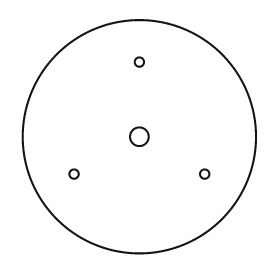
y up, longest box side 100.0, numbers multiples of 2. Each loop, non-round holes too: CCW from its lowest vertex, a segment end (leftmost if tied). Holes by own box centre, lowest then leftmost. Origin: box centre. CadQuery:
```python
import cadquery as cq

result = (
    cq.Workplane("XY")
    .moveTo(0.0, 0.0)
    .circle(50.0)
    .moveTo(-28.0, -16.0)
    .circle(2.0)
    .moveTo(28.0, -16.0)
    .circle(2.0)
    .moveTo(0.0, 0.0)
    .circle(4.0)
    .moveTo(0.0, 32.0)
    .circle(2.0)
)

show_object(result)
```